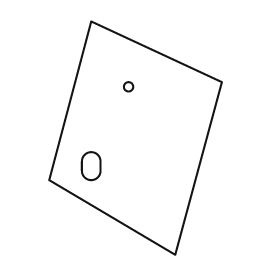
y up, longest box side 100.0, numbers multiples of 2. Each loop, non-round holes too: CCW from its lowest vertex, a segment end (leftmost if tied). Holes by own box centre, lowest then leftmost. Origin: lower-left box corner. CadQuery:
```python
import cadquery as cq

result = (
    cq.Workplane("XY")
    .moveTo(54.0, 0.0)
    .lineTo(74.0, 74.0)
    .lineTo(18.0, 100.0)
    .lineTo(0.0, 32.0)
    .close()
    .moveTo(14.0, 36.0)
    .threePointArc((18.0, 32.0), (22.0, 36.0))
    .lineTo(22.0, 40.0)
    .threePointArc((18.0, 44.0), (14.0, 40.0))
    .close()
    .moveTo(34.0, 72.0)
    .circle(2.0)
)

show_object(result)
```